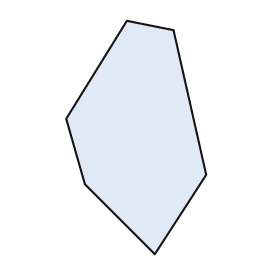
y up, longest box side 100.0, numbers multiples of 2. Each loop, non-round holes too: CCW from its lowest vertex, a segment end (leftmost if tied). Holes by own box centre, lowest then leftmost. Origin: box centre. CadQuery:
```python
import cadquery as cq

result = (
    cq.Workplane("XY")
    .moveTo(8.0, -50.0)
    .lineTo(30.0, -16.0)
    .lineTo(16.0, 46.0)
    .lineTo(-4.0, 50.0)
    .lineTo(-30.0, 8.0)
    .lineTo(-22.0, -20.0)
    .close()
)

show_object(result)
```